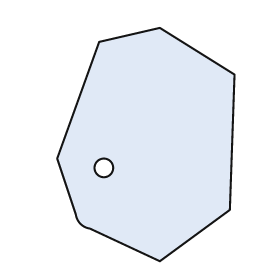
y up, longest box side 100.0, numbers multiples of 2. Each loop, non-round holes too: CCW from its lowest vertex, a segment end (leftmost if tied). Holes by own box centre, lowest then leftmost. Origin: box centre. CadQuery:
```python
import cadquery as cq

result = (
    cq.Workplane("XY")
    .moveTo(6.0, -50.0)
    .lineTo(36.0, -28.0)
    .lineTo(38.0, 30.0)
    .lineTo(6.0, 50.0)
    .lineTo(-20.0, 44.0)
    .lineTo(-38.0, -6.0)
    .lineTo(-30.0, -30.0)
    .threePointArc((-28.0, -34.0), (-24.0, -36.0))
    .close()
    .moveTo(-18.0, -10.0)
    .circle(4.0)
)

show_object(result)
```